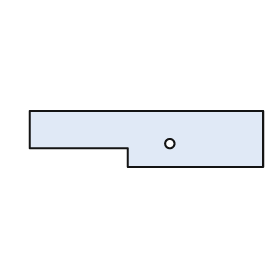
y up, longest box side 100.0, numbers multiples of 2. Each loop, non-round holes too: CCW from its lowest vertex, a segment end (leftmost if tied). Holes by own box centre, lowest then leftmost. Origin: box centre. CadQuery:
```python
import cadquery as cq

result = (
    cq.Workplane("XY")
    .moveTo(-8.0, -12.0)
    .lineTo(50.0, -12.0)
    .lineTo(50.0, 12.0)
    .lineTo(-50.0, 12.0)
    .lineTo(-50.0, -4.0)
    .lineTo(-8.0, -4.0)
    .close()
    .moveTo(10.0, -2.0)
    .circle(2.0)
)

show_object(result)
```